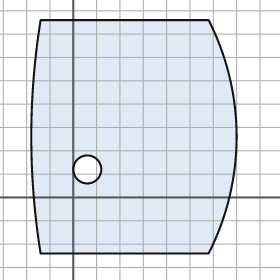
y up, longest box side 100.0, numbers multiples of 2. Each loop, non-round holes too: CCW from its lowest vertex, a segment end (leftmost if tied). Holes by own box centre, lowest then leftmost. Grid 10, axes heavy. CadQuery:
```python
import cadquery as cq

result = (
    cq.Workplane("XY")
    .moveTo(-14.0, -24.0)
    .lineTo(58.0, -24.0)
    .threePointArc((70.0, 26.0), (58.0, 76.0))
    .lineTo(-14.0, 76.0)
    .threePointArc((-18.0, 26.0), (-14.0, -24.0))
    .close()
    .moveTo(6.0, 12.0)
    .circle(6.0)
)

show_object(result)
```